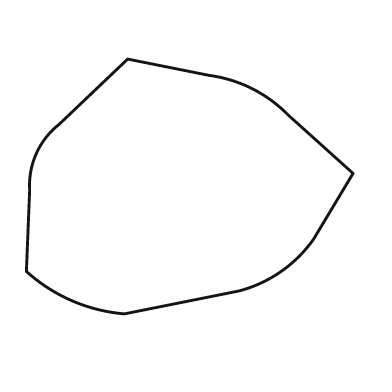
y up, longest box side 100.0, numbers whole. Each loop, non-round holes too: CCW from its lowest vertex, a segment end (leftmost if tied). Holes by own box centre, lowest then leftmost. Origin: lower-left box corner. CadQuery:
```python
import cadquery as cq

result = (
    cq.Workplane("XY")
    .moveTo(30.0, 0.0)
    .lineTo(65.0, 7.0)
    .threePointArc((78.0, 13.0), (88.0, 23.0))
    .lineTo(100.0, 43.0)
    .lineTo(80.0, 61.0)
    .threePointArc((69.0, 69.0), (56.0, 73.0))
    .lineTo(31.0, 78.0)
    .lineTo(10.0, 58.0)
    .threePointArc((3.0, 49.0), (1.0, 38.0))
    .lineTo(0.0, 13.0)
    .threePointArc((14.0, 4.0), (30.0, 0.0))
    .close()
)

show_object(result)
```